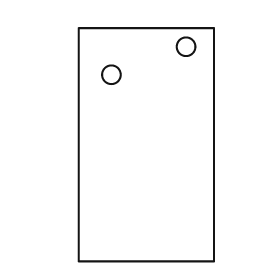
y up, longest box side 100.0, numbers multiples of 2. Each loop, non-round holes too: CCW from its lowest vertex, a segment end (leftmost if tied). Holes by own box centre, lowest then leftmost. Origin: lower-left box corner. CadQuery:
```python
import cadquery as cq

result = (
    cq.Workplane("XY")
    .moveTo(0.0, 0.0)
    .lineTo(58.0, 0.0)
    .lineTo(58.0, 100.0)
    .lineTo(0.0, 100.0)
    .close()
    .moveTo(14.0, 80.0)
    .circle(4.0)
    .moveTo(46.0, 92.0)
    .circle(4.0)
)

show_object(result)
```